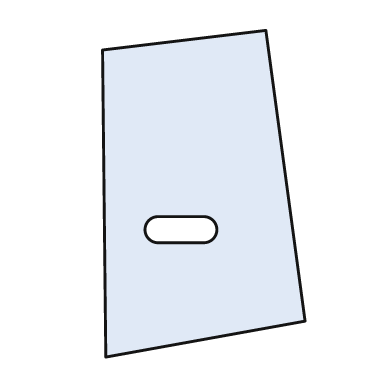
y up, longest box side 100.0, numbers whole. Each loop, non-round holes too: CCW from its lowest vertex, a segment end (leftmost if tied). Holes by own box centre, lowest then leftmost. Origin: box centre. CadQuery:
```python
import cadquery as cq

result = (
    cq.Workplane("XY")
    .moveTo(-30.0, -50.0)
    .lineTo(31.0, -39.0)
    .lineTo(19.0, 50.0)
    .lineTo(-31.0, 44.0)
    .close()
    .moveTo(-14.0, -15.0)
    .lineTo(0.0, -15.0)
    .threePointArc((4.0, -11.0), (0.0, -7.0))
    .lineTo(-14.0, -7.0)
    .threePointArc((-18.0, -11.0), (-14.0, -15.0))
    .close()
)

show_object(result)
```